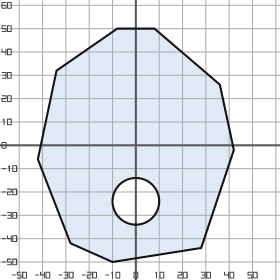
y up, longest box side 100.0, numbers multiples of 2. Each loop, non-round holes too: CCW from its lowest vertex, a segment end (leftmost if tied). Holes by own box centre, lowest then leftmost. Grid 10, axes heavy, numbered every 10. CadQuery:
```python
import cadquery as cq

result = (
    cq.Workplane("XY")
    .moveTo(-10.0, -50.0)
    .lineTo(28.0, -44.0)
    .lineTo(42.0, -2.0)
    .lineTo(36.0, 26.0)
    .lineTo(8.0, 50.0)
    .lineTo(-8.0, 50.0)
    .lineTo(-34.0, 32.0)
    .lineTo(-42.0, -6.0)
    .lineTo(-28.0, -42.0)
    .close()
    .moveTo(0.0, -24.0)
    .circle(10.0)
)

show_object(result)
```